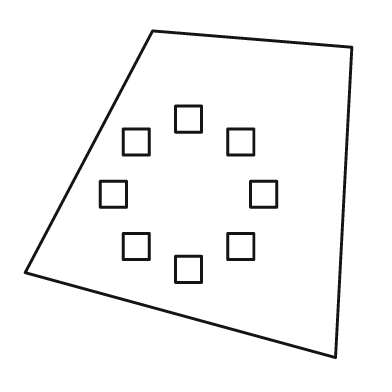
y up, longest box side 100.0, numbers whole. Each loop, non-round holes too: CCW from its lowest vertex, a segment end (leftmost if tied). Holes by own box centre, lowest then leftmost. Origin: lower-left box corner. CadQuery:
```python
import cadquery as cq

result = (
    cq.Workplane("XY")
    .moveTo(95.0, 0.0)
    .lineTo(100.0, 95.0)
    .lineTo(39.0, 100.0)
    .lineTo(0.0, 26.0)
    .close()
    .moveTo(46.0, 23.0)
    .lineTo(54.0, 23.0)
    .lineTo(54.0, 31.0)
    .lineTo(46.0, 31.0)
    .close()
    .moveTo(30.0, 30.0)
    .lineTo(38.0, 30.0)
    .lineTo(38.0, 38.0)
    .lineTo(30.0, 38.0)
    .close()
    .moveTo(62.0, 30.0)
    .lineTo(70.0, 30.0)
    .lineTo(70.0, 38.0)
    .lineTo(62.0, 38.0)
    .close()
    .moveTo(23.0, 46.0)
    .lineTo(31.0, 46.0)
    .lineTo(31.0, 54.0)
    .lineTo(23.0, 54.0)
    .close()
    .moveTo(69.0, 46.0)
    .lineTo(77.0, 46.0)
    .lineTo(77.0, 54.0)
    .lineTo(69.0, 54.0)
    .close()
    .moveTo(30.0, 62.0)
    .lineTo(38.0, 62.0)
    .lineTo(38.0, 70.0)
    .lineTo(30.0, 70.0)
    .close()
    .moveTo(62.0, 62.0)
    .lineTo(70.0, 62.0)
    .lineTo(70.0, 70.0)
    .lineTo(62.0, 70.0)
    .close()
    .moveTo(46.0, 69.0)
    .lineTo(54.0, 69.0)
    .lineTo(54.0, 77.0)
    .lineTo(46.0, 77.0)
    .close()
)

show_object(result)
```